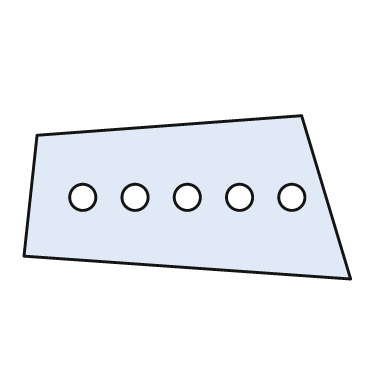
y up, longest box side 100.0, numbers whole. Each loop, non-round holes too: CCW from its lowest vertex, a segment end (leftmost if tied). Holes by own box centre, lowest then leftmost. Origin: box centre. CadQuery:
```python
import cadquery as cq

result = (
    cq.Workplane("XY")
    .moveTo(50.0, -25.0)
    .lineTo(35.0, 25.0)
    .lineTo(-46.0, 19.0)
    .lineTo(-50.0, -18.0)
    .close()
    .moveTo(-32.0, 0.0)
    .circle(4.0)
    .moveTo(-16.0, 0.0)
    .circle(4.0)
    .moveTo(0.0, 0.0)
    .circle(4.0)
    .moveTo(16.0, 0.0)
    .circle(4.0)
    .moveTo(32.0, 0.0)
    .circle(4.0)
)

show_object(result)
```